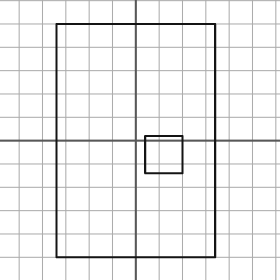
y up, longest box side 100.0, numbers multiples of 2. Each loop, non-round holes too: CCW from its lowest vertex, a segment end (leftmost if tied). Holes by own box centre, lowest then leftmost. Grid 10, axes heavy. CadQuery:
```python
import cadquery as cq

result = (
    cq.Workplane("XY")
    .moveTo(-34.0, -50.0)
    .lineTo(34.0, -50.0)
    .lineTo(34.0, 50.0)
    .lineTo(-34.0, 50.0)
    .close()
    .moveTo(4.0, -14.0)
    .lineTo(20.0, -14.0)
    .lineTo(20.0, 2.0)
    .lineTo(4.0, 2.0)
    .close()
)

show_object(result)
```